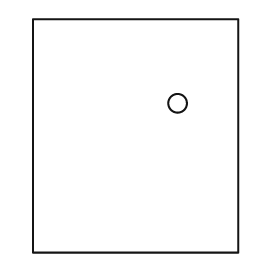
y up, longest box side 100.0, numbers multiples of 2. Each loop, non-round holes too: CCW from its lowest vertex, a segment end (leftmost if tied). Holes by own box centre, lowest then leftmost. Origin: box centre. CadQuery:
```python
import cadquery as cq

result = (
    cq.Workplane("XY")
    .moveTo(-44.0, -50.0)
    .lineTo(44.0, -50.0)
    .lineTo(44.0, 50.0)
    .lineTo(-44.0, 50.0)
    .close()
    .moveTo(18.0, 14.0)
    .circle(4.0)
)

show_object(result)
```